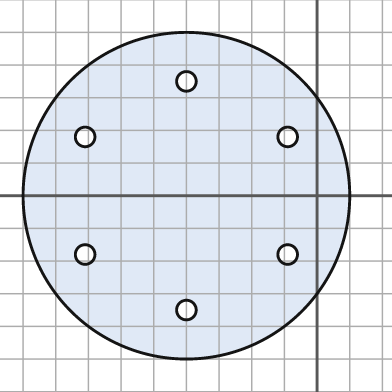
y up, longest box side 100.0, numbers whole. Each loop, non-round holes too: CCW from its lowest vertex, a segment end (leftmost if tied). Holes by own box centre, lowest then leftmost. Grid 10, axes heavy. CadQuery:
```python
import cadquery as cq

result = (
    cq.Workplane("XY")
    .moveTo(-40.0, 0.0)
    .circle(50.0)
    .moveTo(-40.0, -35.0)
    .circle(3.0)
    .moveTo(-71.0, -18.0)
    .circle(3.0)
    .moveTo(-9.0, -18.0)
    .circle(3.0)
    .moveTo(-71.0, 18.0)
    .circle(3.0)
    .moveTo(-9.0, 18.0)
    .circle(3.0)
    .moveTo(-40.0, 35.0)
    .circle(3.0)
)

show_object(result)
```